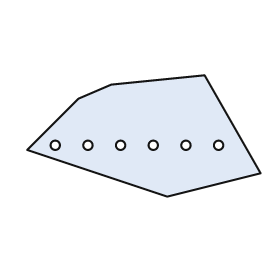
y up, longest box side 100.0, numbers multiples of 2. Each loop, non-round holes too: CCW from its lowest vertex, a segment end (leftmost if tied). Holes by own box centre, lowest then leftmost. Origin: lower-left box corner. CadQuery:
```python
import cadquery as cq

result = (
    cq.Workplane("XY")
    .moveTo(60.0, 0.0)
    .lineTo(100.0, 10.0)
    .lineTo(76.0, 52.0)
    .lineTo(36.0, 48.0)
    .lineTo(22.0, 42.0)
    .lineTo(0.0, 20.0)
    .close()
    .moveTo(12.0, 22.0)
    .circle(2.0)
    .moveTo(26.0, 22.0)
    .circle(2.0)
    .moveTo(40.0, 22.0)
    .circle(2.0)
    .moveTo(54.0, 22.0)
    .circle(2.0)
    .moveTo(68.0, 22.0)
    .circle(2.0)
    .moveTo(82.0, 22.0)
    .circle(2.0)
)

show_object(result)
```